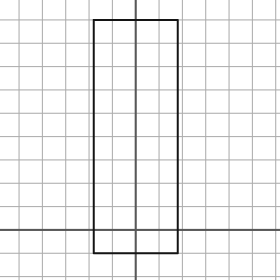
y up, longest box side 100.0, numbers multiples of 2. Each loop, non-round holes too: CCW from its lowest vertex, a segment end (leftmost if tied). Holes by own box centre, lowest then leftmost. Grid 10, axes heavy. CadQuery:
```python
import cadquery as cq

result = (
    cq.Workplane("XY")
    .moveTo(-18.0, -10.0)
    .lineTo(18.0, -10.0)
    .lineTo(18.0, 90.0)
    .lineTo(-18.0, 90.0)
    .close()
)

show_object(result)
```